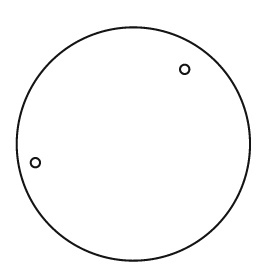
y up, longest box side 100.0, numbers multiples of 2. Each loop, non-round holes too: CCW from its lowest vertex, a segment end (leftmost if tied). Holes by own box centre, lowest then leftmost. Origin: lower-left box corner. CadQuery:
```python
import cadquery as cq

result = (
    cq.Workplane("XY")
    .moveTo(50.0, 50.0)
    .circle(50.0)
    .moveTo(8.0, 42.0)
    .circle(2.0)
    .moveTo(72.0, 82.0)
    .circle(2.0)
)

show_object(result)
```